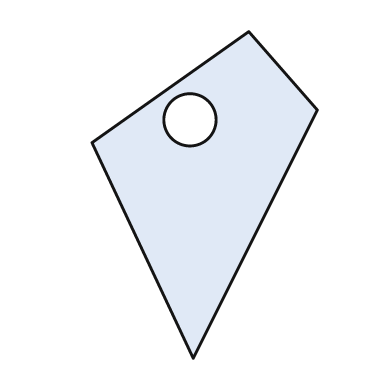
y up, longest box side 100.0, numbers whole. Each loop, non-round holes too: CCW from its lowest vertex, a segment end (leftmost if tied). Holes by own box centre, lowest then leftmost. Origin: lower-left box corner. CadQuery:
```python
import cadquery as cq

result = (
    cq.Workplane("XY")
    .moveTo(31.0, 0.0)
    .lineTo(69.0, 76.0)
    .lineTo(48.0, 100.0)
    .lineTo(0.0, 66.0)
    .close()
    .moveTo(30.0, 73.0)
    .circle(8.0)
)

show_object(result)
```